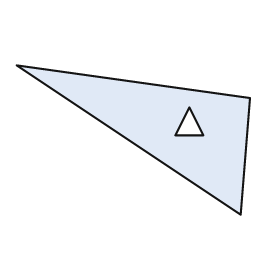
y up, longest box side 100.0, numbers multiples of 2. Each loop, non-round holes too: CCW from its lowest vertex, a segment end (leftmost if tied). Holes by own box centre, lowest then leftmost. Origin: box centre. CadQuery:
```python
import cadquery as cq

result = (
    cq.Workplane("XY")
    .moveTo(46.0, -32.0)
    .lineTo(50.0, 18.0)
    .lineTo(-50.0, 32.0)
    .close()
    .moveTo(18.0, 2.0)
    .lineTo(30.0, 2.0)
    .lineTo(24.0, 14.0)
    .close()
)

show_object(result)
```